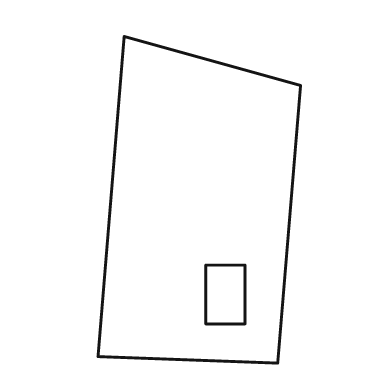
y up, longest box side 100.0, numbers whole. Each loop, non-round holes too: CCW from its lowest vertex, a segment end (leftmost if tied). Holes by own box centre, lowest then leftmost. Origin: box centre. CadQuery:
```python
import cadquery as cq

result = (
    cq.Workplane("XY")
    .moveTo(24.0, -50.0)
    .lineTo(31.0, 35.0)
    .lineTo(-23.0, 50.0)
    .lineTo(-31.0, -48.0)
    .close()
    .moveTo(2.0, -38.0)
    .lineTo(14.0, -38.0)
    .lineTo(14.0, -20.0)
    .lineTo(2.0, -20.0)
    .close()
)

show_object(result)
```